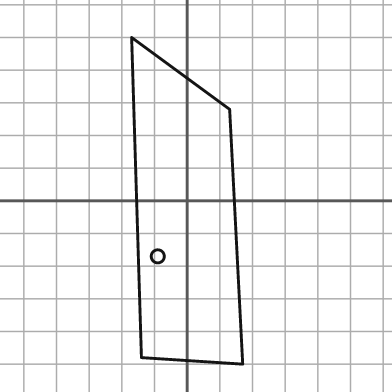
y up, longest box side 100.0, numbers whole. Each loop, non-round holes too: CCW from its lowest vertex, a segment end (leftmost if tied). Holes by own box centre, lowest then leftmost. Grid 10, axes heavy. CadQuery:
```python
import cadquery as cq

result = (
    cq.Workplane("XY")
    .moveTo(17.0, -50.0)
    .lineTo(13.0, 28.0)
    .lineTo(-17.0, 50.0)
    .lineTo(-14.0, -48.0)
    .close()
    .moveTo(-9.0, -17.0)
    .circle(2.0)
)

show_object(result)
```